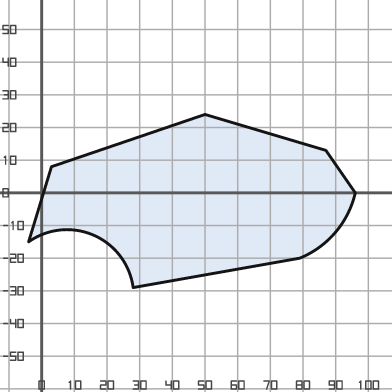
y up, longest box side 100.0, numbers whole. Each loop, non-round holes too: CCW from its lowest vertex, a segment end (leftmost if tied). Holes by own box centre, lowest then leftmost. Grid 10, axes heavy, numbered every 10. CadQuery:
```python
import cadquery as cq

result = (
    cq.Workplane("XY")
    .moveTo(28.0, -29.0)
    .lineTo(79.0, -20.0)
    .threePointArc((90.0, -12.0), (96.0, 0.0))
    .lineTo(87.0, 13.0)
    .lineTo(50.0, 24.0)
    .lineTo(3.0, 8.0)
    .lineTo(-4.0, -15.0)
    .threePointArc((16.0, -13.0), (28.0, -29.0))
    .close()
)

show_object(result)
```